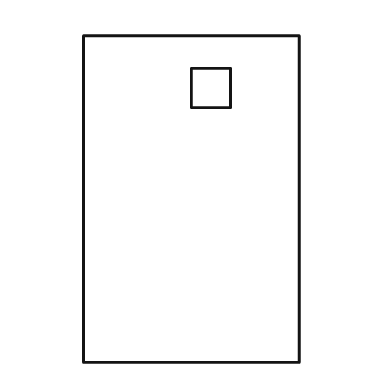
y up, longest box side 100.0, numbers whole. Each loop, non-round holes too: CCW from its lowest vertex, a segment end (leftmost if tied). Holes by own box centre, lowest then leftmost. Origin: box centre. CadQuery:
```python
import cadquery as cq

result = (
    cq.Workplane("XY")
    .moveTo(-33.0, -50.0)
    .lineTo(33.0, -50.0)
    .lineTo(33.0, 50.0)
    .lineTo(-33.0, 50.0)
    .close()
    .moveTo(0.0, 28.0)
    .lineTo(12.0, 28.0)
    .lineTo(12.0, 40.0)
    .lineTo(0.0, 40.0)
    .close()
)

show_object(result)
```